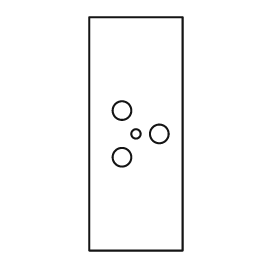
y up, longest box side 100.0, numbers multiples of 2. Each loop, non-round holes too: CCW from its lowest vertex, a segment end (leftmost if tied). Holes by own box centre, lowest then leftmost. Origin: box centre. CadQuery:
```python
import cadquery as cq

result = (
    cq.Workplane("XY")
    .moveTo(-20.0, -50.0)
    .lineTo(20.0, -50.0)
    .lineTo(20.0, 50.0)
    .lineTo(-20.0, 50.0)
    .close()
    .moveTo(-6.0, -10.0)
    .circle(4.0)
    .moveTo(0.0, 0.0)
    .circle(2.0)
    .moveTo(10.0, 0.0)
    .circle(4.0)
    .moveTo(-6.0, 10.0)
    .circle(4.0)
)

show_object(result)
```